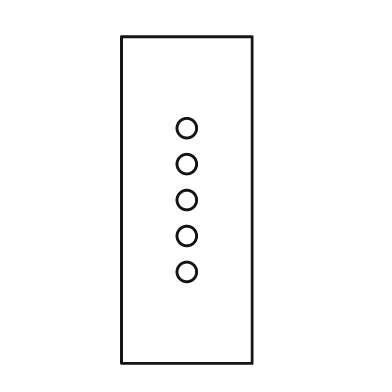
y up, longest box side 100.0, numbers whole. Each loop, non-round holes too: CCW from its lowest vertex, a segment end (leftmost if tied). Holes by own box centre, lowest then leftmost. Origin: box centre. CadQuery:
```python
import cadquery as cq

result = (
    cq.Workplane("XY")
    .moveTo(-20.0, -50.0)
    .lineTo(20.0, -50.0)
    .lineTo(20.0, 50.0)
    .lineTo(-20.0, 50.0)
    .close()
    .moveTo(0.0, -22.0)
    .circle(3.0)
    .moveTo(0.0, -11.0)
    .circle(3.0)
    .moveTo(0.0, 0.0)
    .circle(3.0)
    .moveTo(0.0, 11.0)
    .circle(3.0)
    .moveTo(0.0, 22.0)
    .circle(3.0)
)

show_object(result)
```